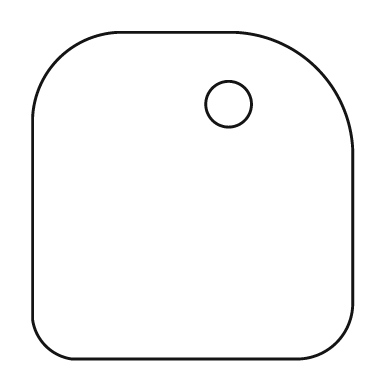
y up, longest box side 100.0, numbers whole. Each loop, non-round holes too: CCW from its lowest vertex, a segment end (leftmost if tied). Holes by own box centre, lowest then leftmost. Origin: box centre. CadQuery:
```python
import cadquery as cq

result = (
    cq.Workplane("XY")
    .moveTo(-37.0, -50.0)
    .lineTo(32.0, -50.0)
    .threePointArc((44.0, -45.0), (49.0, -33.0))
    .lineTo(49.0, 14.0)
    .threePointArc((38.0, 39.0), (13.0, 50.0))
    .lineTo(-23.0, 50.0)
    .threePointArc((-41.0, 42.0), (-49.0, 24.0))
    .lineTo(-49.0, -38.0)
    .threePointArc((-45.0, -46.0), (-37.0, -50.0))
    .close()
    .moveTo(11.0, 28.0)
    .circle(7.0)
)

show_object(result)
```